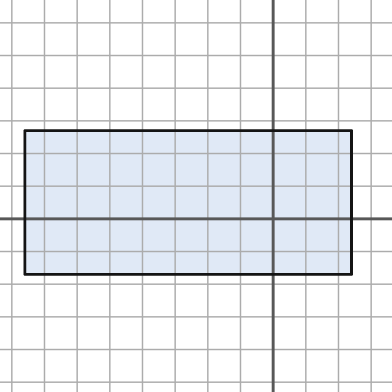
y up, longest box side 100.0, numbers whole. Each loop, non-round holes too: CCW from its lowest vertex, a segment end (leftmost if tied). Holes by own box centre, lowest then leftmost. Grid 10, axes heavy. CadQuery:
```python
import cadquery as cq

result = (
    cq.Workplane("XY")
    .moveTo(-76.0, -17.0)
    .lineTo(24.0, -17.0)
    .lineTo(24.0, 27.0)
    .lineTo(-76.0, 27.0)
    .close()
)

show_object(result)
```